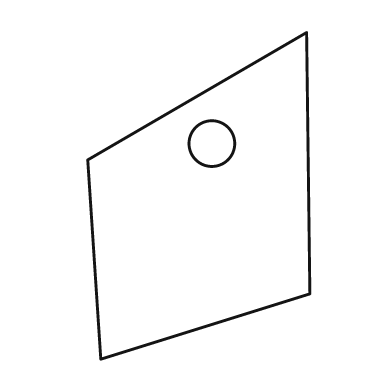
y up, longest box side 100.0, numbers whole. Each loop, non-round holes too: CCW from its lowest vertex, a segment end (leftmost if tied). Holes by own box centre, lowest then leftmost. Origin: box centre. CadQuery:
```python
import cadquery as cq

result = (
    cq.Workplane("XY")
    .moveTo(-30.0, -50.0)
    .lineTo(34.0, -30.0)
    .lineTo(33.0, 50.0)
    .lineTo(-34.0, 11.0)
    .close()
    .moveTo(4.0, 16.0)
    .circle(7.0)
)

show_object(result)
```